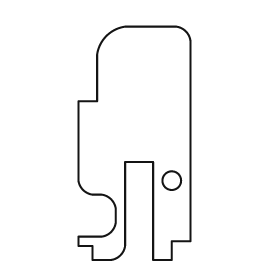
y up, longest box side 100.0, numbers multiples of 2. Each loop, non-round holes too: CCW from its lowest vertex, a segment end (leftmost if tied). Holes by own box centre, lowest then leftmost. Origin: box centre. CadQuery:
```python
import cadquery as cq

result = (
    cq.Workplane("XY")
    .moveTo(-18.0, -50.0)
    .lineTo(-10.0, -50.0)
    .threePointArc((-6.0, -48.0), (-4.0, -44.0))
    .lineTo(-4.0, -8.0)
    .lineTo(8.0, -8.0)
    .lineTo(8.0, -50.0)
    .lineTo(16.0, -50.0)
    .lineTo(16.0, -42.0)
    .lineTo(24.0, -42.0)
    .lineTo(24.0, 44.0)
    .threePointArc((22.0, 48.0), (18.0, 50.0))
    .lineTo(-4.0, 50.0)
    .threePointArc((-12.0, 46.0), (-16.0, 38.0))
    .lineTo(-16.0, 18.0)
    .lineTo(-24.0, 18.0)
    .lineTo(-24.0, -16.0)
    .threePointArc((-22.0, -20.0), (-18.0, -22.0))
    .lineTo(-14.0, -22.0)
    .threePointArc((-10.0, -24.0), (-8.0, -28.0))
    .lineTo(-8.0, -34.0)
    .threePointArc((-10.0, -38.0), (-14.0, -40.0))
    .lineTo(-24.0, -40.0)
    .lineTo(-24.0, -44.0)
    .lineTo(-18.0, -44.0)
    .close()
    .moveTo(16.0, -16.0)
    .circle(4.0)
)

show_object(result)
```